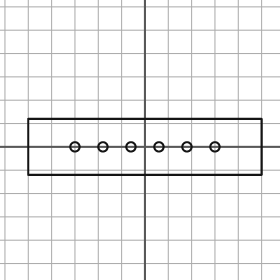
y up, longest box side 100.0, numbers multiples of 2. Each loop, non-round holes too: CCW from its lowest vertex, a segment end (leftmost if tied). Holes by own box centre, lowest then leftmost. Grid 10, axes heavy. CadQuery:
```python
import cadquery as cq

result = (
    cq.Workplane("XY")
    .moveTo(-50.0, -12.0)
    .lineTo(50.0, -12.0)
    .lineTo(50.0, 12.0)
    .lineTo(-50.0, 12.0)
    .close()
    .moveTo(-30.0, 0.0)
    .circle(2.0)
    .moveTo(-18.0, 0.0)
    .circle(2.0)
    .moveTo(-6.0, 0.0)
    .circle(2.0)
    .moveTo(6.0, 0.0)
    .circle(2.0)
    .moveTo(18.0, 0.0)
    .circle(2.0)
    .moveTo(30.0, 0.0)
    .circle(2.0)
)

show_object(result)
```